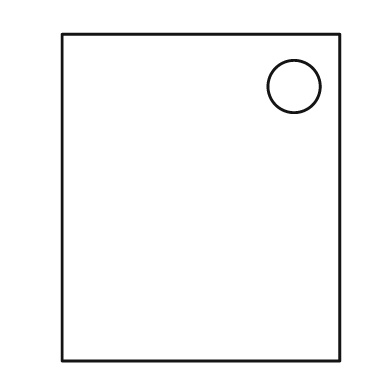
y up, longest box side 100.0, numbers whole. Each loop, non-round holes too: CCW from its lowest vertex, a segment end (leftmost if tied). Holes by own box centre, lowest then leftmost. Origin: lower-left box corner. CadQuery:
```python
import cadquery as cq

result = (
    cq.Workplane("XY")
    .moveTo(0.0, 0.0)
    .lineTo(85.0, 0.0)
    .lineTo(85.0, 100.0)
    .lineTo(0.0, 100.0)
    .close()
    .moveTo(71.0, 84.0)
    .circle(8.0)
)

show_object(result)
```